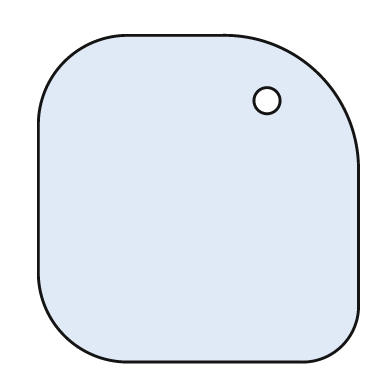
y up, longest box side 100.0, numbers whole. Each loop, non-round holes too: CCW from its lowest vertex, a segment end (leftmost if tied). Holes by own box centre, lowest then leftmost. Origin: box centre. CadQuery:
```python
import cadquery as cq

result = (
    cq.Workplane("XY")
    .moveTo(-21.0, -50.0)
    .lineTo(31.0, -50.0)
    .threePointArc((44.0, -45.0), (49.0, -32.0))
    .lineTo(49.0, 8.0)
    .threePointArc((37.0, 38.0), (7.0, 50.0))
    .lineTo(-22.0, 50.0)
    .threePointArc((-41.0, 42.0), (-49.0, 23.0))
    .lineTo(-49.0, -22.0)
    .threePointArc((-41.0, -42.0), (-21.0, -50.0))
    .close()
    .moveTo(21.0, 30.0)
    .circle(4.0)
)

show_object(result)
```